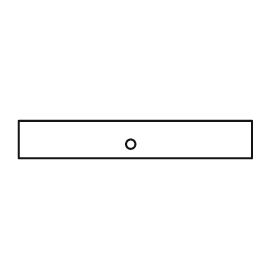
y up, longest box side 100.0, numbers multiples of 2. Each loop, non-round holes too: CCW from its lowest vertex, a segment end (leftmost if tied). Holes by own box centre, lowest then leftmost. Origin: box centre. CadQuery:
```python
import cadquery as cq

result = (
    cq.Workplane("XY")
    .moveTo(-50.0, -8.0)
    .lineTo(50.0, -8.0)
    .lineTo(50.0, 8.0)
    .lineTo(-50.0, 8.0)
    .close()
    .moveTo(-2.0, -2.0)
    .circle(2.0)
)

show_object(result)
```